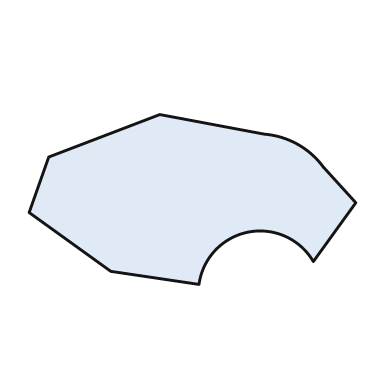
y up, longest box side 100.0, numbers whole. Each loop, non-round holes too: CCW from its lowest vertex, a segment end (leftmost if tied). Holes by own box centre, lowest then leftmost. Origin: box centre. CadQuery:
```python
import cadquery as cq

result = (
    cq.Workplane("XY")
    .moveTo(2.0, -26.0)
    .threePointArc((17.0, -10.0), (37.0, -19.0))
    .lineTo(50.0, -1.0)
    .lineTo(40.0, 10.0)
    .threePointArc((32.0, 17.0), (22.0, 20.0))
    .lineTo(-10.0, 26.0)
    .lineTo(-44.0, 13.0)
    .lineTo(-50.0, -4.0)
    .lineTo(-25.0, -22.0)
    .close()
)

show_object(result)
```